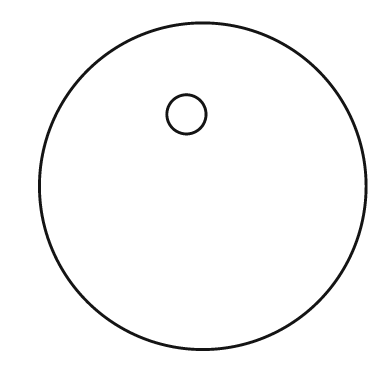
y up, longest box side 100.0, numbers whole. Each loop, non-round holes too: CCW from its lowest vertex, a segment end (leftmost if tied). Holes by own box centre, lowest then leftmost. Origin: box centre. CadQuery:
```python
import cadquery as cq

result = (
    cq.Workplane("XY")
    .moveTo(0.0, 0.0)
    .circle(50.0)
    .moveTo(-5.0, 22.0)
    .circle(6.0)
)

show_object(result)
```